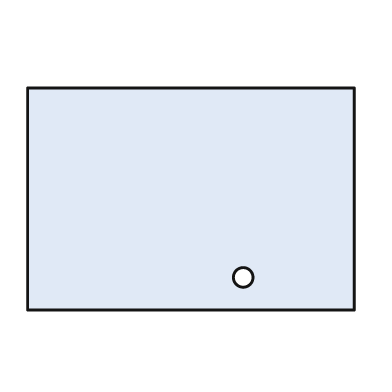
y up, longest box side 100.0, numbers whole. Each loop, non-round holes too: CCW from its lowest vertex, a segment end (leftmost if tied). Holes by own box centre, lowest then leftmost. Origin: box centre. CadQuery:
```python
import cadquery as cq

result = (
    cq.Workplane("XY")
    .moveTo(-50.0, -34.0)
    .lineTo(50.0, -34.0)
    .lineTo(50.0, 34.0)
    .lineTo(-50.0, 34.0)
    .close()
    .moveTo(16.0, -24.0)
    .circle(3.0)
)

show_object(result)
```